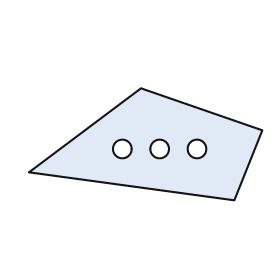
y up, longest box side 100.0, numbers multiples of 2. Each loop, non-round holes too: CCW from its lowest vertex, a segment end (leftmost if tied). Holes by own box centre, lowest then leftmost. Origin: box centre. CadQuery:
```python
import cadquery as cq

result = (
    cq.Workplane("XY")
    .moveTo(38.0, -24.0)
    .lineTo(50.0, 6.0)
    .lineTo(-2.0, 24.0)
    .lineTo(-50.0, -12.0)
    .close()
    .moveTo(-10.0, -2.0)
    .circle(4.0)
    .moveTo(6.0, -2.0)
    .circle(4.0)
    .moveTo(22.0, -2.0)
    .circle(4.0)
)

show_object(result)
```